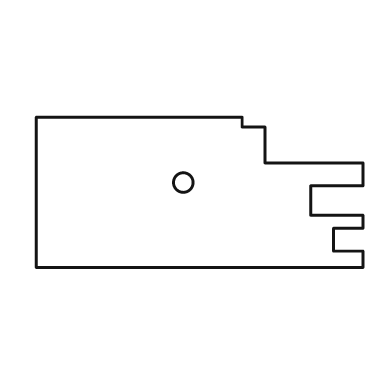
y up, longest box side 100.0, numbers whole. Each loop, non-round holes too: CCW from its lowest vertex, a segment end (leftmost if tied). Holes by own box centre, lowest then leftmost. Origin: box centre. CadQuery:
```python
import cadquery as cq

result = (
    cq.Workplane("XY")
    .moveTo(-50.0, -23.0)
    .lineTo(50.0, -23.0)
    .lineTo(50.0, -18.0)
    .lineTo(41.0, -18.0)
    .lineTo(41.0, -11.0)
    .lineTo(50.0, -11.0)
    .lineTo(50.0, -7.0)
    .lineTo(34.0, -7.0)
    .lineTo(34.0, 2.0)
    .lineTo(50.0, 2.0)
    .lineTo(50.0, 9.0)
    .lineTo(20.0, 9.0)
    .lineTo(20.0, 20.0)
    .lineTo(13.0, 20.0)
    .lineTo(13.0, 23.0)
    .lineTo(-50.0, 23.0)
    .close()
    .moveTo(-5.0, 3.0)
    .circle(3.0)
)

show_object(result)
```